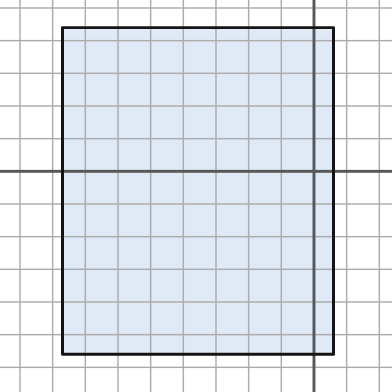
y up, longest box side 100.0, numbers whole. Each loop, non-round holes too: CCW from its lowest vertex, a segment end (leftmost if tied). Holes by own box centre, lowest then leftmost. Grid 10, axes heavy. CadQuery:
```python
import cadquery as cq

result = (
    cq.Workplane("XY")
    .moveTo(-77.0, -56.0)
    .lineTo(6.0, -56.0)
    .lineTo(6.0, 44.0)
    .lineTo(-77.0, 44.0)
    .close()
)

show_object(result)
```